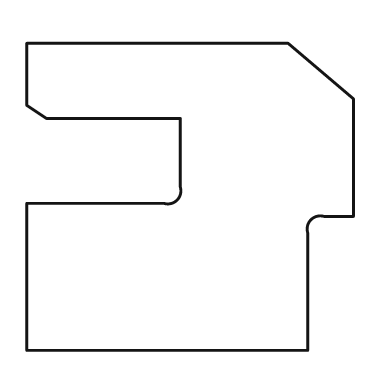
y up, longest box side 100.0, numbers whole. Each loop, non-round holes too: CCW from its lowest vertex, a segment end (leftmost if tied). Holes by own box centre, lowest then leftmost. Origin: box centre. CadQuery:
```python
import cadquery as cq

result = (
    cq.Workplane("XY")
    .moveTo(-50.0, -47.0)
    .lineTo(36.0, -47.0)
    .lineTo(36.0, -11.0)
    .threePointArc((37.0, -7.0), (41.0, -6.0))
    .lineTo(50.0, -6.0)
    .lineTo(50.0, 30.0)
    .lineTo(30.0, 47.0)
    .lineTo(-50.0, 47.0)
    .lineTo(-50.0, 28.0)
    .lineTo(-44.0, 24.0)
    .lineTo(-3.0, 24.0)
    .lineTo(-3.0, 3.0)
    .threePointArc((-4.0, -1.0), (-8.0, -2.0))
    .lineTo(-50.0, -2.0)
    .close()
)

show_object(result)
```